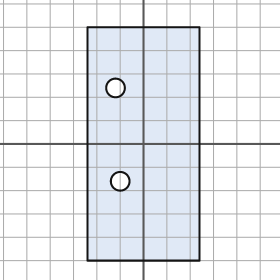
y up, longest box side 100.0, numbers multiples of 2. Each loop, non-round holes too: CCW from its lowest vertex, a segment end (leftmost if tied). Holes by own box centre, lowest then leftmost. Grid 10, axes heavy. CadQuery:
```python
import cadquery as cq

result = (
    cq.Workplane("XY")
    .moveTo(-24.0, -50.0)
    .lineTo(24.0, -50.0)
    .lineTo(24.0, 50.0)
    .lineTo(-24.0, 50.0)
    .close()
    .moveTo(-10.0, -16.0)
    .circle(4.0)
    .moveTo(-12.0, 24.0)
    .circle(4.0)
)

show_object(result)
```